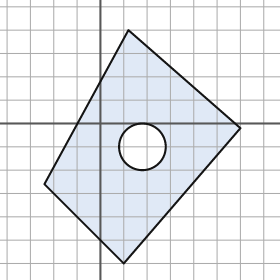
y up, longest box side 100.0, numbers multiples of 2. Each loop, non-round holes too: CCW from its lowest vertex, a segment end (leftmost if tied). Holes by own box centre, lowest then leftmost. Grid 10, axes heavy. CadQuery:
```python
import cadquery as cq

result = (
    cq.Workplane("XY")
    .moveTo(10.0, -60.0)
    .lineTo(60.0, -2.0)
    .lineTo(12.0, 40.0)
    .lineTo(-24.0, -26.0)
    .close()
    .moveTo(18.0, -10.0)
    .circle(10.0)
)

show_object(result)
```